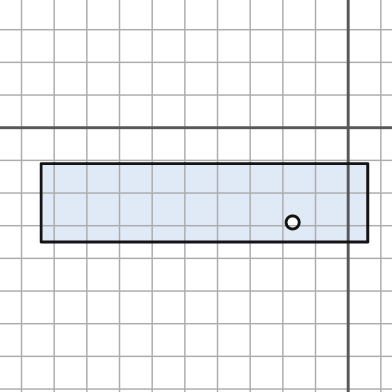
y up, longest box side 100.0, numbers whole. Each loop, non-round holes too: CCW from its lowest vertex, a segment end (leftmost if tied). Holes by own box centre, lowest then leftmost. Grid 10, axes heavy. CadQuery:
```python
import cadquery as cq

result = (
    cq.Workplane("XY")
    .moveTo(-94.0, -35.0)
    .lineTo(6.0, -35.0)
    .lineTo(6.0, -11.0)
    .lineTo(-94.0, -11.0)
    .close()
    .moveTo(-17.0, -29.0)
    .circle(2.0)
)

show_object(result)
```